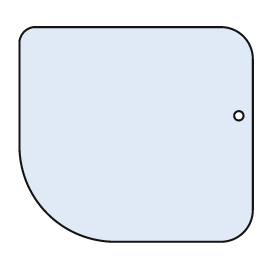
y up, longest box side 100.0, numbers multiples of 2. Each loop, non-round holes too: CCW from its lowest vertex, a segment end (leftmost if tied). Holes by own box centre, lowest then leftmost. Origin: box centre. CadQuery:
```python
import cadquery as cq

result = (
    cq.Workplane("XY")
    .moveTo(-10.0, -46.0)
    .lineTo(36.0, -46.0)
    .threePointArc((46.0, -42.0), (50.0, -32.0))
    .lineTo(50.0, 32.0)
    .threePointArc((46.0, 42.0), (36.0, 46.0))
    .lineTo(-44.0, 46.0)
    .threePointArc((-48.0, 44.0), (-50.0, 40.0))
    .lineTo(-50.0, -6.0)
    .threePointArc((-38.0, -34.0), (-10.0, -46.0))
    .close()
    .moveTo(44.0, 8.0)
    .circle(2.0)
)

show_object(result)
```